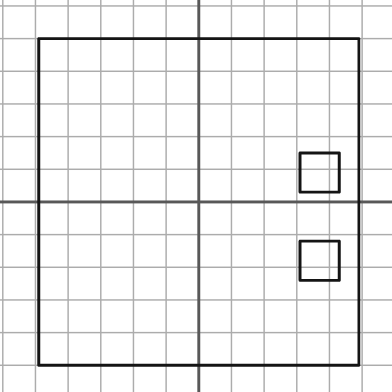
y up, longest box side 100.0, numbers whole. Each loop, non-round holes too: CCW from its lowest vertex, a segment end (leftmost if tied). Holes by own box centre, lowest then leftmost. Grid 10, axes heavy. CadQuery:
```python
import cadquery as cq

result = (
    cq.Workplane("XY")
    .moveTo(-49.0, -50.0)
    .lineTo(49.0, -50.0)
    .lineTo(49.0, 50.0)
    .lineTo(-49.0, 50.0)
    .close()
    .moveTo(31.0, -24.0)
    .lineTo(43.0, -24.0)
    .lineTo(43.0, -12.0)
    .lineTo(31.0, -12.0)
    .close()
    .moveTo(31.0, 3.0)
    .lineTo(43.0, 3.0)
    .lineTo(43.0, 15.0)
    .lineTo(31.0, 15.0)
    .close()
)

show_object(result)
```